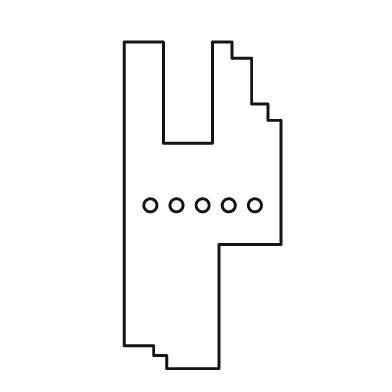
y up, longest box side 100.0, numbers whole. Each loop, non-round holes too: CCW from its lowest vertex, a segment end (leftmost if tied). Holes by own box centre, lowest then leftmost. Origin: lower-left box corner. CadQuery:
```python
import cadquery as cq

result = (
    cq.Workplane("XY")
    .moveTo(13.0, 0.0)
    .lineTo(29.0, 0.0)
    .lineTo(29.0, 38.0)
    .lineTo(48.0, 38.0)
    .lineTo(48.0, 76.0)
    .lineTo(44.0, 76.0)
    .lineTo(44.0, 81.0)
    .lineTo(39.0, 81.0)
    .lineTo(39.0, 95.0)
    .lineTo(33.0, 95.0)
    .lineTo(33.0, 100.0)
    .lineTo(27.0, 100.0)
    .lineTo(27.0, 69.0)
    .lineTo(12.0, 69.0)
    .lineTo(12.0, 100.0)
    .lineTo(0.0, 100.0)
    .lineTo(0.0, 7.0)
    .lineTo(9.0, 7.0)
    .lineTo(9.0, 4.0)
    .lineTo(13.0, 4.0)
    .close()
    .moveTo(8.0, 50.0)
    .circle(2.0)
    .moveTo(16.0, 50.0)
    .circle(2.0)
    .moveTo(24.0, 50.0)
    .circle(2.0)
    .moveTo(32.0, 50.0)
    .circle(2.0)
    .moveTo(40.0, 50.0)
    .circle(2.0)
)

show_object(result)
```